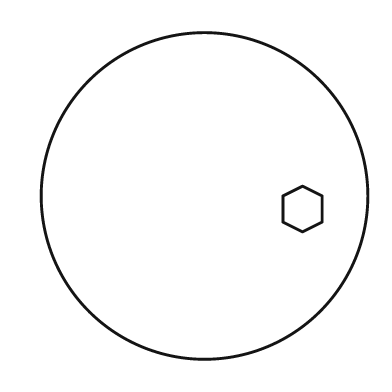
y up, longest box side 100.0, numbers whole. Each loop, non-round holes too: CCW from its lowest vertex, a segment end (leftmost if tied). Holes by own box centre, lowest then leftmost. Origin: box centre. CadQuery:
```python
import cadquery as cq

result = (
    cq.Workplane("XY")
    .moveTo(0.0, 0.0)
    .circle(50.0)
    .moveTo(30.0, -11.0)
    .lineTo(36.0, -8.0)
    .lineTo(36.0, 0.0)
    .lineTo(30.0, 3.0)
    .lineTo(24.0, 0.0)
    .lineTo(24.0, -8.0)
    .close()
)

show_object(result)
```